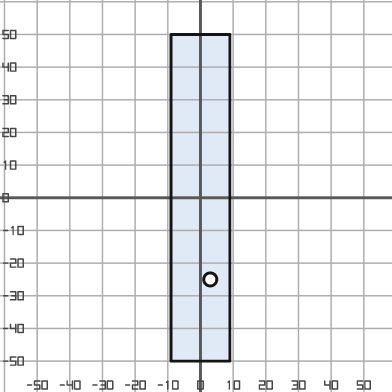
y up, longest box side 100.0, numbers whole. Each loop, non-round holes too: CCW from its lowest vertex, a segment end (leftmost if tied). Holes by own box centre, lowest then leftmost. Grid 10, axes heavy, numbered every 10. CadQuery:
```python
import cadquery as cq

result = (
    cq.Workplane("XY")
    .moveTo(-9.0, -50.0)
    .lineTo(9.0, -50.0)
    .lineTo(9.0, 50.0)
    .lineTo(-9.0, 50.0)
    .close()
    .moveTo(3.0, -25.0)
    .circle(2.0)
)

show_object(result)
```